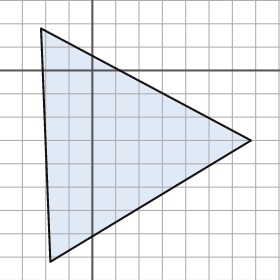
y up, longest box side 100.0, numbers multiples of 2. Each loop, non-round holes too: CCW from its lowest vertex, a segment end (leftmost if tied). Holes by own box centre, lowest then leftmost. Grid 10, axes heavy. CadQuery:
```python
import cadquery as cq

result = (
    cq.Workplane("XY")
    .moveTo(-18.0, -82.0)
    .lineTo(68.0, -30.0)
    .lineTo(-22.0, 18.0)
    .close()
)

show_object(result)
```